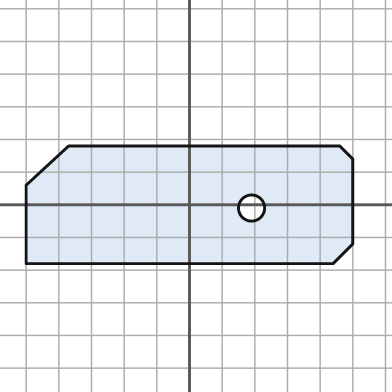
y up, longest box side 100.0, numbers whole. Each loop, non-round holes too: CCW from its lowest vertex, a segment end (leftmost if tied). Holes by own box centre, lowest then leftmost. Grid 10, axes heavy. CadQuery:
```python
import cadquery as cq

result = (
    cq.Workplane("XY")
    .moveTo(-50.0, -18.0)
    .lineTo(44.0, -18.0)
    .lineTo(50.0, -12.0)
    .lineTo(50.0, 14.0)
    .lineTo(46.0, 18.0)
    .lineTo(-37.0, 18.0)
    .lineTo(-50.0, 6.0)
    .close()
    .moveTo(19.0, -1.0)
    .circle(4.0)
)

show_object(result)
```